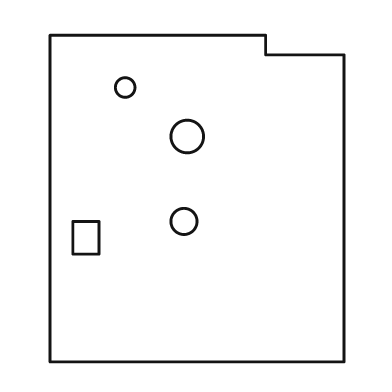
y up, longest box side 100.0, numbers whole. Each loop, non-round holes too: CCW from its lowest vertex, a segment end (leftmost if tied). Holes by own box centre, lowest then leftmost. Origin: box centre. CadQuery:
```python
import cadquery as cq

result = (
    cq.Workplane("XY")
    .moveTo(-45.0, -50.0)
    .lineTo(45.0, -50.0)
    .lineTo(45.0, 44.0)
    .lineTo(21.0, 44.0)
    .lineTo(21.0, 50.0)
    .lineTo(-45.0, 50.0)
    .close()
    .moveTo(-38.0, -17.0)
    .lineTo(-30.0, -17.0)
    .lineTo(-30.0, -7.0)
    .lineTo(-38.0, -7.0)
    .close()
    .moveTo(-4.0, -7.0)
    .circle(4.0)
    .moveTo(-3.0, 19.0)
    .circle(5.0)
    .moveTo(-22.0, 34.0)
    .circle(3.0)
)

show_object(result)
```